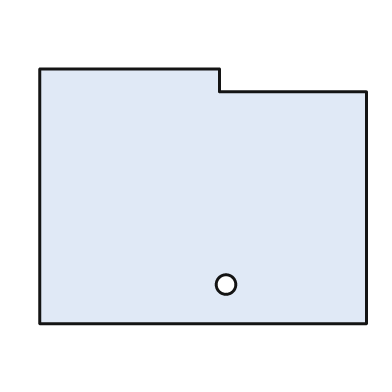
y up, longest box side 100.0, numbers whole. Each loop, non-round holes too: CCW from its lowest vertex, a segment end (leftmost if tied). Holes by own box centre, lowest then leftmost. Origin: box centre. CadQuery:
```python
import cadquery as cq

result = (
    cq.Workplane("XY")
    .moveTo(-50.0, -39.0)
    .lineTo(50.0, -39.0)
    .lineTo(50.0, 32.0)
    .lineTo(5.0, 32.0)
    .lineTo(5.0, 39.0)
    .lineTo(-50.0, 39.0)
    .close()
    .moveTo(7.0, -27.0)
    .circle(3.0)
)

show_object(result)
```